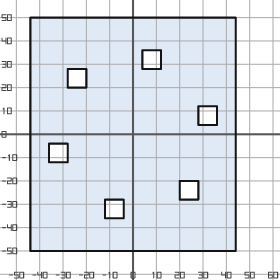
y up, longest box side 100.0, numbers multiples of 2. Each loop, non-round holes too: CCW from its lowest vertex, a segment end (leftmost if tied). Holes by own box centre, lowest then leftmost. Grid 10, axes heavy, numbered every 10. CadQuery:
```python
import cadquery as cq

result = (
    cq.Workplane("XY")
    .moveTo(-44.0, -50.0)
    .lineTo(44.0, -50.0)
    .lineTo(44.0, 50.0)
    .lineTo(-44.0, 50.0)
    .close()
    .moveTo(-12.0, -36.0)
    .lineTo(-4.0, -36.0)
    .lineTo(-4.0, -28.0)
    .lineTo(-12.0, -28.0)
    .close()
    .moveTo(20.0, -28.0)
    .lineTo(28.0, -28.0)
    .lineTo(28.0, -20.0)
    .lineTo(20.0, -20.0)
    .close()
    .moveTo(-36.0, -12.0)
    .lineTo(-28.0, -12.0)
    .lineTo(-28.0, -4.0)
    .lineTo(-36.0, -4.0)
    .close()
    .moveTo(28.0, 4.0)
    .lineTo(36.0, 4.0)
    .lineTo(36.0, 12.0)
    .lineTo(28.0, 12.0)
    .close()
    .moveTo(-28.0, 20.0)
    .lineTo(-20.0, 20.0)
    .lineTo(-20.0, 28.0)
    .lineTo(-28.0, 28.0)
    .close()
    .moveTo(4.0, 28.0)
    .lineTo(12.0, 28.0)
    .lineTo(12.0, 36.0)
    .lineTo(4.0, 36.0)
    .close()
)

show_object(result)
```